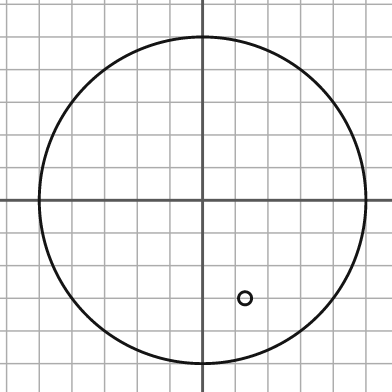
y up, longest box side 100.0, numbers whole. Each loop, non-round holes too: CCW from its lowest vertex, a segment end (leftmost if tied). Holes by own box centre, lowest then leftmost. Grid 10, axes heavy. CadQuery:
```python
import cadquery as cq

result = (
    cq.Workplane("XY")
    .moveTo(0.0, 0.0)
    .circle(50.0)
    .moveTo(13.0, -30.0)
    .circle(2.0)
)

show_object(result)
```